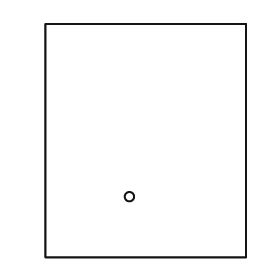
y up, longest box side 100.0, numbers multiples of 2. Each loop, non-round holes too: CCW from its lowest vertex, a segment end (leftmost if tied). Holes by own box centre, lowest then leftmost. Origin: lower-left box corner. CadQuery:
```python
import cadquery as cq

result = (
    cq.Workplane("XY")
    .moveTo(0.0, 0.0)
    .lineTo(86.0, 0.0)
    .lineTo(86.0, 100.0)
    .lineTo(0.0, 100.0)
    .close()
    .moveTo(36.0, 26.0)
    .circle(2.0)
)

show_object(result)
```